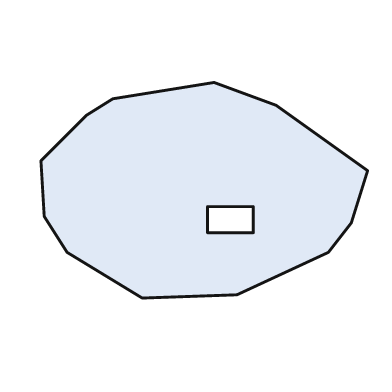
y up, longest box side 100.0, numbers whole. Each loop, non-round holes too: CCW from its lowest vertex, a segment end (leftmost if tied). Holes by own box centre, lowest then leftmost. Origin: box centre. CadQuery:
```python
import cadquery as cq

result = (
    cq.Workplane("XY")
    .moveTo(-19.0, -33.0)
    .lineTo(10.0, -32.0)
    .lineTo(38.0, -19.0)
    .lineTo(45.0, -10.0)
    .lineTo(50.0, 6.0)
    .lineTo(22.0, 26.0)
    .lineTo(3.0, 33.0)
    .lineTo(-28.0, 28.0)
    .lineTo(-36.0, 23.0)
    .lineTo(-50.0, 9.0)
    .lineTo(-49.0, -8.0)
    .lineTo(-42.0, -19.0)
    .close()
    .moveTo(1.0, -13.0)
    .lineTo(15.0, -13.0)
    .lineTo(15.0, -5.0)
    .lineTo(1.0, -5.0)
    .close()
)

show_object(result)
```